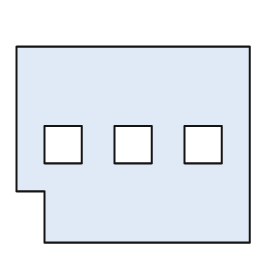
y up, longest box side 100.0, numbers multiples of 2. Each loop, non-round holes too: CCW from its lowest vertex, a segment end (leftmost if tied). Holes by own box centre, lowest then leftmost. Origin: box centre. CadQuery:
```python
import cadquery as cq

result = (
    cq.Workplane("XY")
    .moveTo(-38.0, -42.0)
    .lineTo(50.0, -42.0)
    .lineTo(50.0, 42.0)
    .lineTo(-50.0, 42.0)
    .lineTo(-50.0, -20.0)
    .lineTo(-38.0, -20.0)
    .close()
    .moveTo(-38.0, -8.0)
    .lineTo(-22.0, -8.0)
    .lineTo(-22.0, 8.0)
    .lineTo(-38.0, 8.0)
    .close()
    .moveTo(-8.0, -8.0)
    .lineTo(8.0, -8.0)
    .lineTo(8.0, 8.0)
    .lineTo(-8.0, 8.0)
    .close()
    .moveTo(22.0, -8.0)
    .lineTo(38.0, -8.0)
    .lineTo(38.0, 8.0)
    .lineTo(22.0, 8.0)
    .close()
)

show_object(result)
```